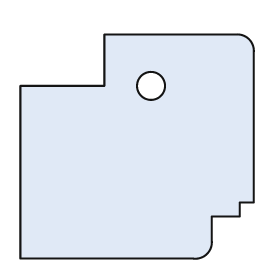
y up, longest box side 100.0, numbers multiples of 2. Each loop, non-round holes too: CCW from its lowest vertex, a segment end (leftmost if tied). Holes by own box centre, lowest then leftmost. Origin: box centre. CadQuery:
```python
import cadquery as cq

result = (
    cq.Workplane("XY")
    .moveTo(-50.0, -48.0)
    .lineTo(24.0, -48.0)
    .threePointArc((30.0, -46.0), (32.0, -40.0))
    .lineTo(32.0, -30.0)
    .lineTo(44.0, -30.0)
    .lineTo(44.0, -24.0)
    .lineTo(50.0, -24.0)
    .lineTo(50.0, 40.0)
    .threePointArc((48.0, 46.0), (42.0, 48.0))
    .lineTo(-14.0, 48.0)
    .lineTo(-14.0, 26.0)
    .lineTo(-50.0, 26.0)
    .close()
    .moveTo(6.0, 26.0)
    .circle(6.0)
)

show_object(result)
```